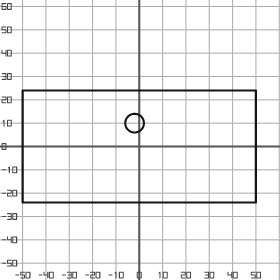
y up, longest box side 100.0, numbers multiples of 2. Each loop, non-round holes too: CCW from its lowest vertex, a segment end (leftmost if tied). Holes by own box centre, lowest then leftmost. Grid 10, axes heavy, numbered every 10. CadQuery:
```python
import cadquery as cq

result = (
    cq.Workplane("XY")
    .moveTo(-50.0, -24.0)
    .lineTo(50.0, -24.0)
    .lineTo(50.0, 24.0)
    .lineTo(-50.0, 24.0)
    .close()
    .moveTo(-2.0, 10.0)
    .circle(4.0)
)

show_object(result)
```